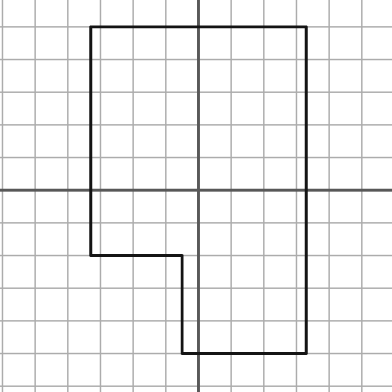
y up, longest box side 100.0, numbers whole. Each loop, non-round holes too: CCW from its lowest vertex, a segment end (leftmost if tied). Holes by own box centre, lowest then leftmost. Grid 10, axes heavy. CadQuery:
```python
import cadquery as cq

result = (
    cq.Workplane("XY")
    .moveTo(-5.0, -50.0)
    .lineTo(33.0, -50.0)
    .lineTo(33.0, 50.0)
    .lineTo(-33.0, 50.0)
    .lineTo(-33.0, -20.0)
    .lineTo(-5.0, -20.0)
    .close()
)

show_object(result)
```